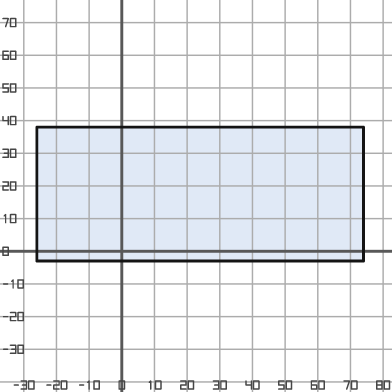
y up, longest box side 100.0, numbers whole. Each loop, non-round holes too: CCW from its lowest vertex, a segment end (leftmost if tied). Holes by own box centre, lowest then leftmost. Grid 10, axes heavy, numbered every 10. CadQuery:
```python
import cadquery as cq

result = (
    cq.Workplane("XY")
    .moveTo(-26.0, -3.0)
    .lineTo(74.0, -3.0)
    .lineTo(74.0, 38.0)
    .lineTo(-26.0, 38.0)
    .close()
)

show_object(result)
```